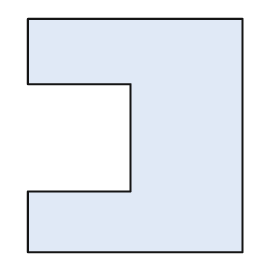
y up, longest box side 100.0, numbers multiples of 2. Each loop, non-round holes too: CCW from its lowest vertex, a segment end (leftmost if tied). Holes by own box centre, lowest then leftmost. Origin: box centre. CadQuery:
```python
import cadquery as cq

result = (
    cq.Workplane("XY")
    .moveTo(-46.0, -50.0)
    .lineTo(46.0, -50.0)
    .lineTo(46.0, 50.0)
    .lineTo(-46.0, 50.0)
    .lineTo(-46.0, 22.0)
    .lineTo(-2.0, 22.0)
    .lineTo(-2.0, -24.0)
    .lineTo(-46.0, -24.0)
    .close()
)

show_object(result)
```